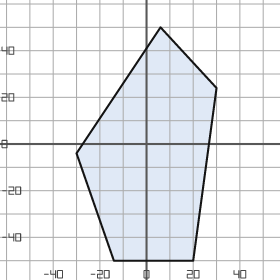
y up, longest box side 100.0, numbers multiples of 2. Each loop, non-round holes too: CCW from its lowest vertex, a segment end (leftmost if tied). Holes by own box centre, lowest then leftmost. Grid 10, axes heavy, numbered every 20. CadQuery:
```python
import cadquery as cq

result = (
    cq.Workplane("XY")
    .moveTo(-14.0, -50.0)
    .lineTo(20.0, -50.0)
    .lineTo(30.0, 24.0)
    .lineTo(6.0, 50.0)
    .lineTo(-30.0, -4.0)
    .close()
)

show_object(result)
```